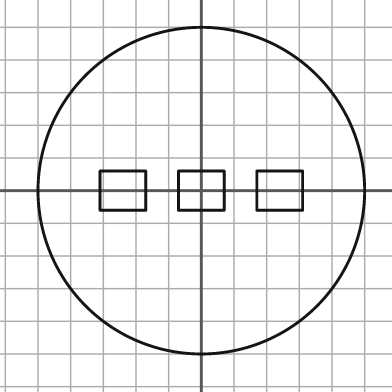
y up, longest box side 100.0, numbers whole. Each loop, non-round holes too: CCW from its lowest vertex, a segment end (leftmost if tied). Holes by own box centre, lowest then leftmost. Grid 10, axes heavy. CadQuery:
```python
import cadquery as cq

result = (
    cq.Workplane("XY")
    .moveTo(0.0, 0.0)
    .circle(50.0)
    .moveTo(-31.0, -6.0)
    .lineTo(-17.0, -6.0)
    .lineTo(-17.0, 6.0)
    .lineTo(-31.0, 6.0)
    .close()
    .moveTo(-7.0, -6.0)
    .lineTo(7.0, -6.0)
    .lineTo(7.0, 6.0)
    .lineTo(-7.0, 6.0)
    .close()
    .moveTo(17.0, -6.0)
    .lineTo(31.0, -6.0)
    .lineTo(31.0, 6.0)
    .lineTo(17.0, 6.0)
    .close()
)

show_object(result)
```